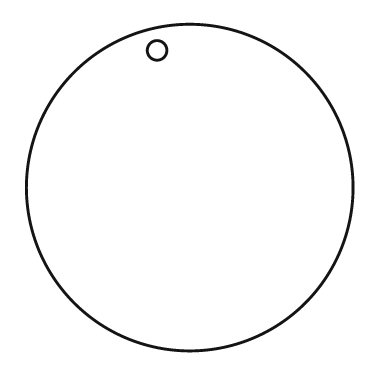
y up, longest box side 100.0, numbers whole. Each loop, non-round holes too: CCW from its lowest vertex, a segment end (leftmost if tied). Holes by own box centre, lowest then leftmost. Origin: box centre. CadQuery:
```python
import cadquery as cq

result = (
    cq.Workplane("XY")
    .moveTo(0.0, 0.0)
    .circle(50.0)
    .moveTo(-10.0, 42.0)
    .circle(3.0)
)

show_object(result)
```